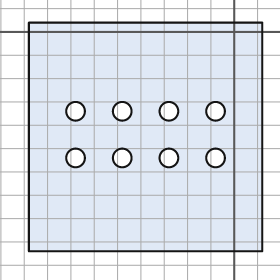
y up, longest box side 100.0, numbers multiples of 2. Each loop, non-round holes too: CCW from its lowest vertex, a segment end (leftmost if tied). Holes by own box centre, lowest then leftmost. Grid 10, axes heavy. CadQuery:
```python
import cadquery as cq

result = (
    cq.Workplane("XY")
    .moveTo(-88.0, -94.0)
    .lineTo(12.0, -94.0)
    .lineTo(12.0, 4.0)
    .lineTo(-88.0, 4.0)
    .close()
    .moveTo(-68.0, -54.0)
    .circle(4.0)
    .moveTo(-48.0, -54.0)
    .circle(4.0)
    .moveTo(-28.0, -54.0)
    .circle(4.0)
    .moveTo(-8.0, -54.0)
    .circle(4.0)
    .moveTo(-68.0, -34.0)
    .circle(4.0)
    .moveTo(-48.0, -34.0)
    .circle(4.0)
    .moveTo(-28.0, -34.0)
    .circle(4.0)
    .moveTo(-8.0, -34.0)
    .circle(4.0)
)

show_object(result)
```